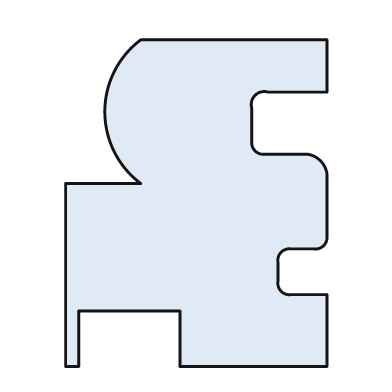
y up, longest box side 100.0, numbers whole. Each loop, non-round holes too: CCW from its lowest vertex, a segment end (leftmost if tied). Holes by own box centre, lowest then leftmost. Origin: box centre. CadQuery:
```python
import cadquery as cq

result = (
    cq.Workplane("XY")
    .moveTo(-40.0, -50.0)
    .lineTo(-36.0, -50.0)
    .lineTo(-36.0, -33.0)
    .lineTo(-5.0, -33.0)
    .lineTo(-5.0, -50.0)
    .lineTo(40.0, -50.0)
    .lineTo(40.0, -28.0)
    .lineTo(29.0, -28.0)
    .threePointArc((26.0, -27.0), (25.0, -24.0))
    .lineTo(25.0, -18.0)
    .threePointArc((26.0, -15.0), (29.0, -14.0))
    .lineTo(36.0, -14.0)
    .threePointArc((39.0, -13.0), (40.0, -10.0))
    .lineTo(40.0, 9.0)
    .threePointArc((38.0, 13.0), (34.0, 15.0))
    .lineTo(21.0, 15.0)
    .threePointArc((18.0, 16.0), (17.0, 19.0))
    .lineTo(17.0, 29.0)
    .threePointArc((18.0, 33.0), (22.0, 34.0))
    .lineTo(40.0, 34.0)
    .lineTo(40.0, 50.0)
    .lineTo(-17.0, 50.0)
    .threePointArc((-28.0, 28.0), (-17.0, 6.0))
    .lineTo(-40.0, 6.0)
    .close()
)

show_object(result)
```